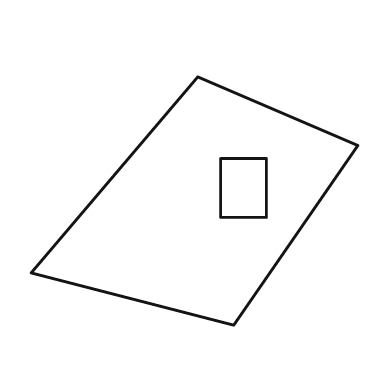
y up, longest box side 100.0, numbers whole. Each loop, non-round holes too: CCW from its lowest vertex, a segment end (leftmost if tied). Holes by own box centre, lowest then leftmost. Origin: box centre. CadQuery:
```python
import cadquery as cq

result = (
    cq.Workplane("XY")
    .moveTo(12.0, -38.0)
    .lineTo(50.0, 17.0)
    .lineTo(1.0, 38.0)
    .lineTo(-50.0, -22.0)
    .close()
    .moveTo(8.0, -5.0)
    .lineTo(22.0, -5.0)
    .lineTo(22.0, 13.0)
    .lineTo(8.0, 13.0)
    .close()
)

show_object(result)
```